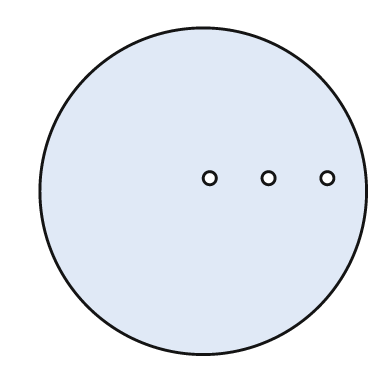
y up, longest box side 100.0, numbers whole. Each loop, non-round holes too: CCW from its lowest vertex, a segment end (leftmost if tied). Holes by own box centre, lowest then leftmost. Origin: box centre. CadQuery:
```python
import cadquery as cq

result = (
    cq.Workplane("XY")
    .moveTo(0.0, 0.0)
    .circle(50.0)
    .moveTo(2.0, 4.0)
    .circle(2.0)
    .moveTo(20.0, 4.0)
    .circle(2.0)
    .moveTo(38.0, 4.0)
    .circle(2.0)
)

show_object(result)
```